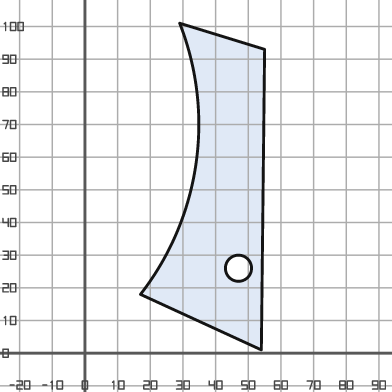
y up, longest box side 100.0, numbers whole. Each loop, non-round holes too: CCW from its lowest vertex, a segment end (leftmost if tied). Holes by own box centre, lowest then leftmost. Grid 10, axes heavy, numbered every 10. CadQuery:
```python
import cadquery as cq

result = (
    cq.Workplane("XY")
    .moveTo(54.0, 1.0)
    .lineTo(55.0, 93.0)
    .lineTo(29.0, 101.0)
    .threePointArc((34.0, 58.0), (17.0, 18.0))
    .close()
    .moveTo(47.0, 26.0)
    .circle(4.0)
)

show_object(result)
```